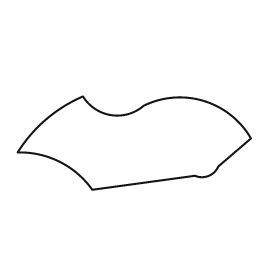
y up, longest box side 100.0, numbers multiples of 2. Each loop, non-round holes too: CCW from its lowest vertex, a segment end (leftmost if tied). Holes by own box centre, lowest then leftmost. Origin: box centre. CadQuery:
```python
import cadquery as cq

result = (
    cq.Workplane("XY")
    .moveTo(-18.0, -20.0)
    .lineTo(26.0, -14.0)
    .threePointArc((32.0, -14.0), (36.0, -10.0))
    .lineTo(50.0, 2.0)
    .threePointArc((30.0, 18.0), (4.0, 16.0))
    .threePointArc((-10.0, 12.0), (-22.0, 20.0))
    .threePointArc((-38.0, 10.0), (-50.0, -4.0))
    .threePointArc((-32.0, -8.0), (-18.0, -20.0))
    .close()
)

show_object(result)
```